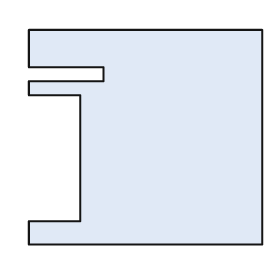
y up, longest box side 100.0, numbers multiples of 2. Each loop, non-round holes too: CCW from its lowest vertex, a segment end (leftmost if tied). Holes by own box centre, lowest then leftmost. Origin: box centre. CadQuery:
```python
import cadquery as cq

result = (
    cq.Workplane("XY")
    .moveTo(-50.0, -46.0)
    .lineTo(50.0, -46.0)
    .lineTo(50.0, 46.0)
    .lineTo(-50.0, 46.0)
    .lineTo(-50.0, 30.0)
    .lineTo(-18.0, 30.0)
    .lineTo(-18.0, 24.0)
    .lineTo(-50.0, 24.0)
    .lineTo(-50.0, 18.0)
    .lineTo(-28.0, 18.0)
    .lineTo(-28.0, -36.0)
    .lineTo(-50.0, -36.0)
    .close()
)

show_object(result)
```